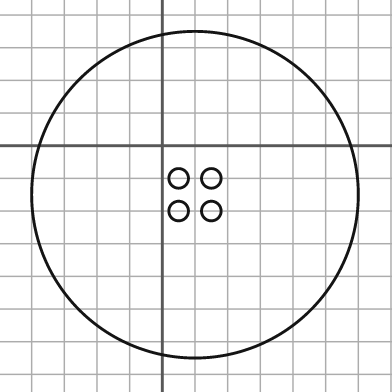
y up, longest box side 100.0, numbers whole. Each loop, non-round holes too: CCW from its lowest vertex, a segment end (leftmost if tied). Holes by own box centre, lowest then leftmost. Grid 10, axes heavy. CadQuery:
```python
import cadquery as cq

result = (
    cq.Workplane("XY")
    .moveTo(10.0, -15.0)
    .circle(50.0)
    .moveTo(5.0, -20.0)
    .circle(3.0)
    .moveTo(15.0, -20.0)
    .circle(3.0)
    .moveTo(5.0, -10.0)
    .circle(3.0)
    .moveTo(15.0, -10.0)
    .circle(3.0)
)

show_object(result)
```